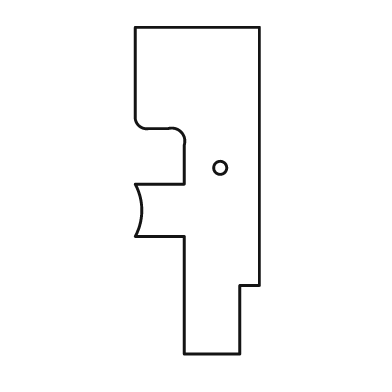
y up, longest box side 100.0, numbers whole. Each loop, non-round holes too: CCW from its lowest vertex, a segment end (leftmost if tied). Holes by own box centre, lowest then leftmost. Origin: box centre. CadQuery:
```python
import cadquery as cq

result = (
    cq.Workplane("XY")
    .moveTo(-4.0, -50.0)
    .lineTo(13.0, -50.0)
    .lineTo(13.0, -29.0)
    .lineTo(19.0, -29.0)
    .lineTo(19.0, 50.0)
    .lineTo(-19.0, 50.0)
    .lineTo(-19.0, 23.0)
    .threePointArc((-18.0, 20.0), (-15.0, 19.0))
    .lineTo(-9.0, 19.0)
    .threePointArc((-5.0, 18.0), (-4.0, 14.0))
    .lineTo(-4.0, 2.0)
    .lineTo(-19.0, 2.0)
    .threePointArc((-17.0, -6.0), (-19.0, -14.0))
    .lineTo(-4.0, -14.0)
    .close()
    .moveTo(7.0, 7.0)
    .circle(2.0)
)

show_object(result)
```